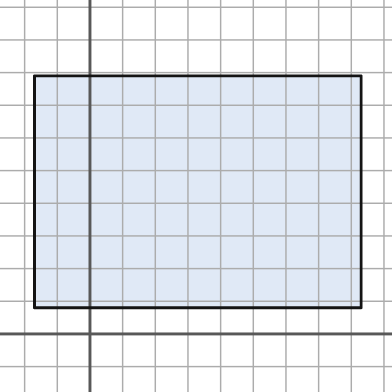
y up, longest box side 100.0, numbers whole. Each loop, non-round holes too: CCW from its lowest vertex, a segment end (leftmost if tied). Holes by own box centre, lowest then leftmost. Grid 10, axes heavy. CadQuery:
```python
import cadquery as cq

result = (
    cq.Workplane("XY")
    .moveTo(-17.0, 8.0)
    .lineTo(83.0, 8.0)
    .lineTo(83.0, 79.0)
    .lineTo(-17.0, 79.0)
    .close()
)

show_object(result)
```